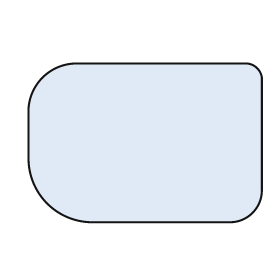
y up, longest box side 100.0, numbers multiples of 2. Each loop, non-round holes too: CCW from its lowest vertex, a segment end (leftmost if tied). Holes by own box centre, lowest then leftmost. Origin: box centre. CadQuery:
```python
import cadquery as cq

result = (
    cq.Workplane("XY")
    .moveTo(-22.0, -34.0)
    .lineTo(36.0, -34.0)
    .threePointArc((46.0, -30.0), (50.0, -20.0))
    .lineTo(50.0, 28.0)
    .threePointArc((48.0, 32.0), (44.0, 34.0))
    .lineTo(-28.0, 34.0)
    .threePointArc((-44.0, 28.0), (-50.0, 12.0))
    .lineTo(-50.0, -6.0)
    .threePointArc((-42.0, -26.0), (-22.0, -34.0))
    .close()
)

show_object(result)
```